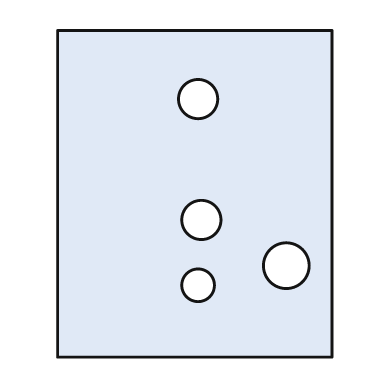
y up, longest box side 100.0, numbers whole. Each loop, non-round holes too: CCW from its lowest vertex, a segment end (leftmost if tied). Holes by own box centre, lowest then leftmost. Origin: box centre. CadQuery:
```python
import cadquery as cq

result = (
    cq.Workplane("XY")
    .moveTo(-42.0, -50.0)
    .lineTo(42.0, -50.0)
    .lineTo(42.0, 50.0)
    .lineTo(-42.0, 50.0)
    .close()
    .moveTo(1.0, -28.0)
    .circle(5.0)
    .moveTo(28.0, -22.0)
    .circle(7.0)
    .moveTo(2.0, -8.0)
    .circle(6.0)
    .moveTo(1.0, 29.0)
    .circle(6.0)
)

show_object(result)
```